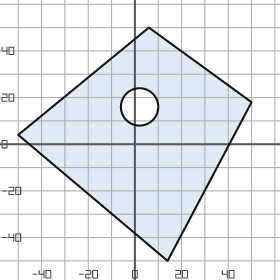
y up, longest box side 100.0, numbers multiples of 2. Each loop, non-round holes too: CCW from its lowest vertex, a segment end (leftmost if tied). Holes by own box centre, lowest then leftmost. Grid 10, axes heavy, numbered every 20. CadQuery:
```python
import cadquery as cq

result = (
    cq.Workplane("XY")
    .moveTo(14.0, -50.0)
    .lineTo(50.0, 18.0)
    .lineTo(6.0, 50.0)
    .lineTo(-50.0, 4.0)
    .close()
    .moveTo(2.0, 16.0)
    .circle(8.0)
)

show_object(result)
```